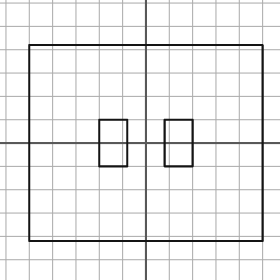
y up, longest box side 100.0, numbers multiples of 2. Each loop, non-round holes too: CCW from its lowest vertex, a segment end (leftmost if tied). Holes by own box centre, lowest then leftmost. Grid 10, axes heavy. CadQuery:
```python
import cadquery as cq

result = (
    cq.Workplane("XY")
    .moveTo(-50.0, -42.0)
    .lineTo(50.0, -42.0)
    .lineTo(50.0, 42.0)
    .lineTo(-50.0, 42.0)
    .close()
    .moveTo(-20.0, -10.0)
    .lineTo(-8.0, -10.0)
    .lineTo(-8.0, 10.0)
    .lineTo(-20.0, 10.0)
    .close()
    .moveTo(8.0, -10.0)
    .lineTo(20.0, -10.0)
    .lineTo(20.0, 10.0)
    .lineTo(8.0, 10.0)
    .close()
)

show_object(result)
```